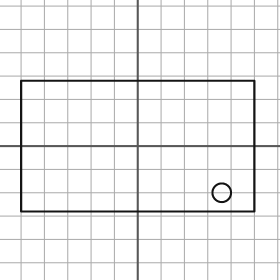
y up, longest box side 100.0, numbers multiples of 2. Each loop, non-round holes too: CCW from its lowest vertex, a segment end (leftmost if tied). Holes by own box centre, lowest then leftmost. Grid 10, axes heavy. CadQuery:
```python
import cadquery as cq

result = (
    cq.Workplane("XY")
    .moveTo(-50.0, -28.0)
    .lineTo(50.0, -28.0)
    .lineTo(50.0, 28.0)
    .lineTo(-50.0, 28.0)
    .close()
    .moveTo(36.0, -20.0)
    .circle(4.0)
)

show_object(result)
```